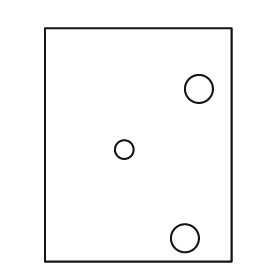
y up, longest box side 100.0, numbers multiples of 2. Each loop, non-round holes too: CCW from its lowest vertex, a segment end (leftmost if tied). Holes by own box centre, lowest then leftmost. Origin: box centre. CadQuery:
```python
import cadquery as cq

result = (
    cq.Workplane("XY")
    .moveTo(-40.0, -50.0)
    .lineTo(40.0, -50.0)
    .lineTo(40.0, 50.0)
    .lineTo(-40.0, 50.0)
    .close()
    .moveTo(20.0, -40.0)
    .circle(6.0)
    .moveTo(-6.0, -2.0)
    .circle(4.0)
    .moveTo(26.0, 24.0)
    .circle(6.0)
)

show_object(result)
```